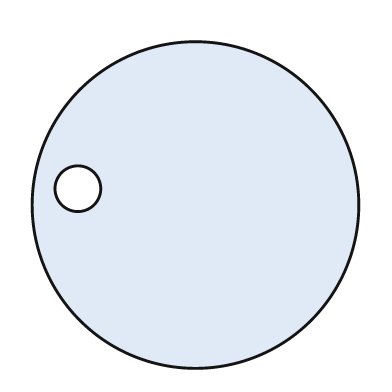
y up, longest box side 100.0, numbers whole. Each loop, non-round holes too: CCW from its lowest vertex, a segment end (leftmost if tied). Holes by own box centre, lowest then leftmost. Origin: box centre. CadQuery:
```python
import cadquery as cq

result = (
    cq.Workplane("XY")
    .moveTo(0.0, 0.0)
    .circle(50.0)
    .moveTo(-36.0, 5.0)
    .circle(7.0)
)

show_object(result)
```